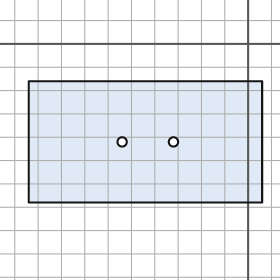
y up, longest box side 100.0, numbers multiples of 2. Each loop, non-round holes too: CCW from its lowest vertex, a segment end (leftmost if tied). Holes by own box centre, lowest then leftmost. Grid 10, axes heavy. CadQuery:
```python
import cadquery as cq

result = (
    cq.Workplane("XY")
    .moveTo(-94.0, -68.0)
    .lineTo(6.0, -68.0)
    .lineTo(6.0, -16.0)
    .lineTo(-94.0, -16.0)
    .close()
    .moveTo(-54.0, -42.0)
    .circle(2.0)
    .moveTo(-32.0, -42.0)
    .circle(2.0)
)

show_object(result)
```